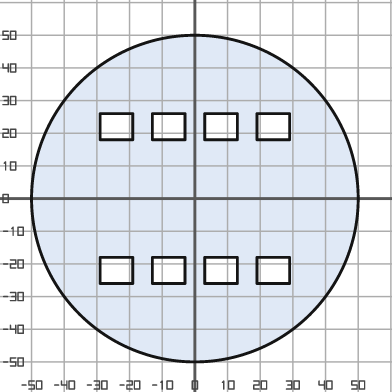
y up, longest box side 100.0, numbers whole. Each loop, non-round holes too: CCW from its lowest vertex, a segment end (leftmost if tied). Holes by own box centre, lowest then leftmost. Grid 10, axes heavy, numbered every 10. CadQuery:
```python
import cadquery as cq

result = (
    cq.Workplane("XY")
    .moveTo(0.0, 0.0)
    .circle(50.0)
    .moveTo(-29.0, -26.0)
    .lineTo(-19.0, -26.0)
    .lineTo(-19.0, -18.0)
    .lineTo(-29.0, -18.0)
    .close()
    .moveTo(-13.0, -26.0)
    .lineTo(-3.0, -26.0)
    .lineTo(-3.0, -18.0)
    .lineTo(-13.0, -18.0)
    .close()
    .moveTo(3.0, -26.0)
    .lineTo(13.0, -26.0)
    .lineTo(13.0, -18.0)
    .lineTo(3.0, -18.0)
    .close()
    .moveTo(19.0, -26.0)
    .lineTo(29.0, -26.0)
    .lineTo(29.0, -18.0)
    .lineTo(19.0, -18.0)
    .close()
    .moveTo(-29.0, 18.0)
    .lineTo(-19.0, 18.0)
    .lineTo(-19.0, 26.0)
    .lineTo(-29.0, 26.0)
    .close()
    .moveTo(-13.0, 18.0)
    .lineTo(-3.0, 18.0)
    .lineTo(-3.0, 26.0)
    .lineTo(-13.0, 26.0)
    .close()
    .moveTo(3.0, 18.0)
    .lineTo(13.0, 18.0)
    .lineTo(13.0, 26.0)
    .lineTo(3.0, 26.0)
    .close()
    .moveTo(19.0, 18.0)
    .lineTo(29.0, 18.0)
    .lineTo(29.0, 26.0)
    .lineTo(19.0, 26.0)
    .close()
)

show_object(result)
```